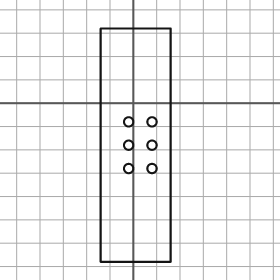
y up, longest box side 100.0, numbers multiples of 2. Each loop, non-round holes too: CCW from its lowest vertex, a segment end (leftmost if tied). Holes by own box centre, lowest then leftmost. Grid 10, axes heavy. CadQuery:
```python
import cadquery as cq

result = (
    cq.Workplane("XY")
    .moveTo(-14.0, -68.0)
    .lineTo(16.0, -68.0)
    .lineTo(16.0, 32.0)
    .lineTo(-14.0, 32.0)
    .close()
    .moveTo(-2.0, -28.0)
    .circle(2.0)
    .moveTo(8.0, -28.0)
    .circle(2.0)
    .moveTo(-2.0, -18.0)
    .circle(2.0)
    .moveTo(8.0, -18.0)
    .circle(2.0)
    .moveTo(-2.0, -8.0)
    .circle(2.0)
    .moveTo(8.0, -8.0)
    .circle(2.0)
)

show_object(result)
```